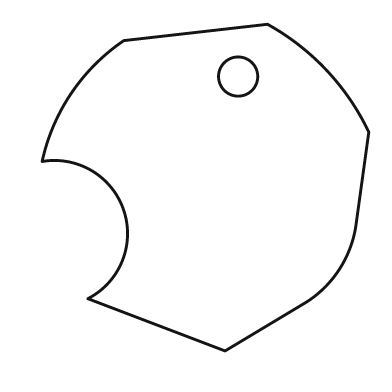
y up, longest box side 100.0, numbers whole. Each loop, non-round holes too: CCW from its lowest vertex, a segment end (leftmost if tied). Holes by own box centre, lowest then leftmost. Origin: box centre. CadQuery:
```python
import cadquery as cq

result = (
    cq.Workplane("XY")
    .moveTo(6.0, -50.0)
    .lineTo(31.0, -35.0)
    .threePointArc((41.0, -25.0), (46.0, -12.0))
    .lineTo(50.0, 17.0)
    .threePointArc((37.0, 36.0), (19.0, 50.0))
    .lineTo(-25.0, 45.0)
    .threePointArc((-41.0, 29.0), (-50.0, 8.0))
    .threePointArc((-25.0, -7.0), (-36.0, -34.0))
    .close()
    .moveTo(10.0, 34.0)
    .circle(6.0)
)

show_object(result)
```